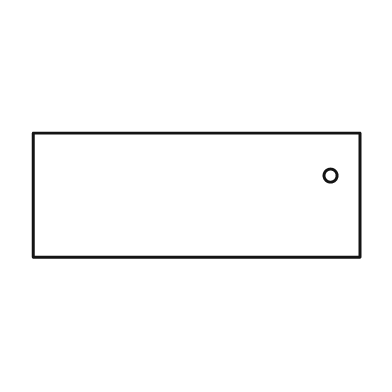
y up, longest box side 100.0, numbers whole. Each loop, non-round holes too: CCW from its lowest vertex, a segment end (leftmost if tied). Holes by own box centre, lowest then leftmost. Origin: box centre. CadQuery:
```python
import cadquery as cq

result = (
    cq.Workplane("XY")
    .moveTo(-50.0, -19.0)
    .lineTo(50.0, -19.0)
    .lineTo(50.0, 19.0)
    .lineTo(-50.0, 19.0)
    .close()
    .moveTo(41.0, 6.0)
    .circle(2.0)
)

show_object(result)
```